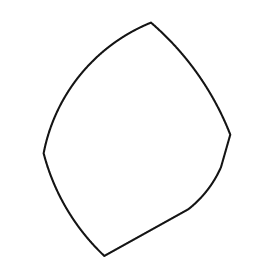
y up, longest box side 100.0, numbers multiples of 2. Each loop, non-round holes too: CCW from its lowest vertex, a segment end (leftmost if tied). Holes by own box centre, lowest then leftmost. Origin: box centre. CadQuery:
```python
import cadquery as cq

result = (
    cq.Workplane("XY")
    .moveTo(-14.0, -50.0)
    .lineTo(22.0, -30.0)
    .threePointArc((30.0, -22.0), (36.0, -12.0))
    .lineTo(40.0, 2.0)
    .threePointArc((26.0, 28.0), (6.0, 50.0))
    .threePointArc((-24.0, 28.0), (-40.0, -6.0))
    .threePointArc((-30.0, -30.0), (-14.0, -50.0))
    .close()
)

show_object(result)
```